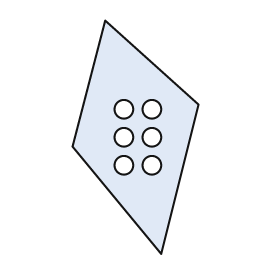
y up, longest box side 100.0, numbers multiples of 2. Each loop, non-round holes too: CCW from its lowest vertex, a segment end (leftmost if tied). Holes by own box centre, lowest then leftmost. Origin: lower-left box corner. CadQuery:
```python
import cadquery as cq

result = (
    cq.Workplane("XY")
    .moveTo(38.0, 0.0)
    .lineTo(54.0, 64.0)
    .lineTo(14.0, 100.0)
    .lineTo(0.0, 46.0)
    .close()
    .moveTo(22.0, 38.0)
    .circle(4.0)
    .moveTo(34.0, 38.0)
    .circle(4.0)
    .moveTo(22.0, 50.0)
    .circle(4.0)
    .moveTo(34.0, 50.0)
    .circle(4.0)
    .moveTo(22.0, 62.0)
    .circle(4.0)
    .moveTo(34.0, 62.0)
    .circle(4.0)
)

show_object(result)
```